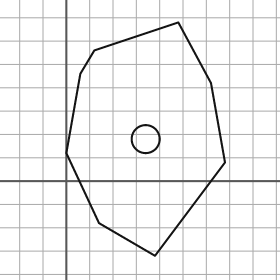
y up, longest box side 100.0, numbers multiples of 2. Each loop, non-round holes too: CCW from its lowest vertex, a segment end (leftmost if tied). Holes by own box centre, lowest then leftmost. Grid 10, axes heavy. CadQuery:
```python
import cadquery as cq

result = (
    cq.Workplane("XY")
    .moveTo(38.0, -32.0)
    .lineTo(68.0, 8.0)
    .lineTo(62.0, 42.0)
    .lineTo(48.0, 68.0)
    .lineTo(12.0, 56.0)
    .lineTo(6.0, 46.0)
    .lineTo(0.0, 12.0)
    .lineTo(14.0, -18.0)
    .close()
    .moveTo(34.0, 18.0)
    .circle(6.0)
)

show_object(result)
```